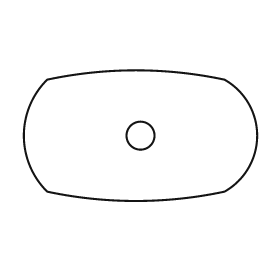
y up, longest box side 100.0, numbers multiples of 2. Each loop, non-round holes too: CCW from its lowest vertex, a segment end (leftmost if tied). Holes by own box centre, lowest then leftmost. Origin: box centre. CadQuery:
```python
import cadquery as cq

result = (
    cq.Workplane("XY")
    .moveTo(-40.0, -24.0)
    .threePointArc((-2.0, -28.0), (36.0, -24.0))
    .threePointArc((50.0, 0.0), (36.0, 24.0))
    .threePointArc((-2.0, 28.0), (-40.0, 24.0))
    .threePointArc((-50.0, 0.0), (-40.0, -24.0))
    .close()
    .moveTo(0.0, 0.0)
    .circle(6.0)
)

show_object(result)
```